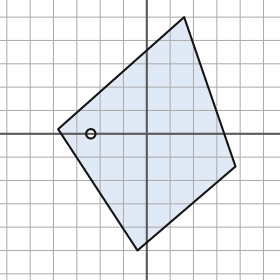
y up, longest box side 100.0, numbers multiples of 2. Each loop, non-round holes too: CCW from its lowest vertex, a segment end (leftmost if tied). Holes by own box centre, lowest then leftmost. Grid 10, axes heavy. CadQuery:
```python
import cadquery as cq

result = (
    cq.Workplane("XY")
    .moveTo(-4.0, -50.0)
    .lineTo(38.0, -14.0)
    .lineTo(16.0, 50.0)
    .lineTo(-38.0, 2.0)
    .close()
    .moveTo(-24.0, 0.0)
    .circle(2.0)
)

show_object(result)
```